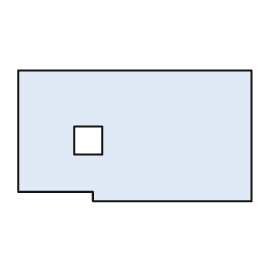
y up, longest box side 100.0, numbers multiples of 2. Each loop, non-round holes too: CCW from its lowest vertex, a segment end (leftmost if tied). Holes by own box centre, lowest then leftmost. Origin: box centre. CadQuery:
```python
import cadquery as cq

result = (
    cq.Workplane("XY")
    .moveTo(-18.0, -28.0)
    .lineTo(50.0, -28.0)
    .lineTo(50.0, 28.0)
    .lineTo(-50.0, 28.0)
    .lineTo(-50.0, -24.0)
    .lineTo(-18.0, -24.0)
    .close()
    .moveTo(-26.0, -8.0)
    .lineTo(-14.0, -8.0)
    .lineTo(-14.0, 4.0)
    .lineTo(-26.0, 4.0)
    .close()
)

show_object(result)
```